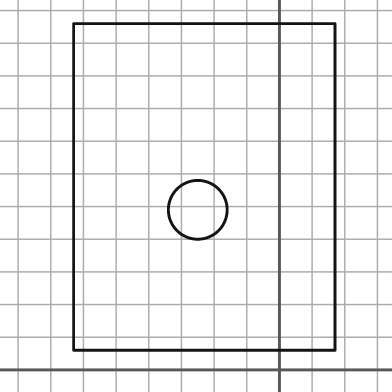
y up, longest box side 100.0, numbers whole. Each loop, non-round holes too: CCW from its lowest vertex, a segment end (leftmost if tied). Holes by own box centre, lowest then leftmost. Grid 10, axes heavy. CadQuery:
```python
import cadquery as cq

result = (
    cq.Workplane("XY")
    .moveTo(-63.0, 6.0)
    .lineTo(17.0, 6.0)
    .lineTo(17.0, 106.0)
    .lineTo(-63.0, 106.0)
    .close()
    .moveTo(-25.0, 49.0)
    .circle(9.0)
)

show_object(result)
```